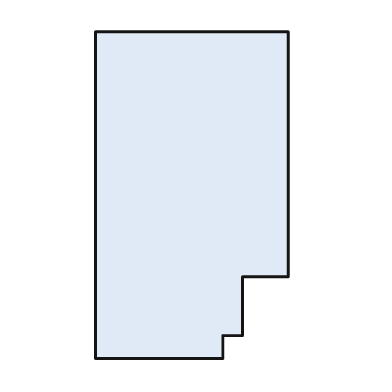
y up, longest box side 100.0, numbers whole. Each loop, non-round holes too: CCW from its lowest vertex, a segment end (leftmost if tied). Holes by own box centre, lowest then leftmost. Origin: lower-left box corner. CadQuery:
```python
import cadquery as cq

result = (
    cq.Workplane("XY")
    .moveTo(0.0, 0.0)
    .lineTo(39.0, 0.0)
    .lineTo(39.0, 7.0)
    .lineTo(45.0, 7.0)
    .lineTo(45.0, 25.0)
    .lineTo(59.0, 25.0)
    .lineTo(59.0, 100.0)
    .lineTo(0.0, 100.0)
    .close()
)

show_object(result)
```